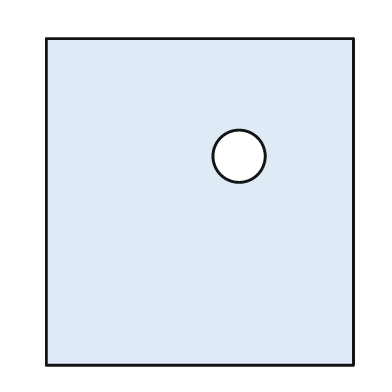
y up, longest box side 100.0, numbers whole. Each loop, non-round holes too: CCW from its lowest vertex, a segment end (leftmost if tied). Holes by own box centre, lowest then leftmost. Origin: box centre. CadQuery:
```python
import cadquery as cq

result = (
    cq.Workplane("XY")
    .moveTo(-47.0, -50.0)
    .lineTo(47.0, -50.0)
    .lineTo(47.0, 50.0)
    .lineTo(-47.0, 50.0)
    .close()
    .moveTo(12.0, 14.0)
    .circle(8.0)
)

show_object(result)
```